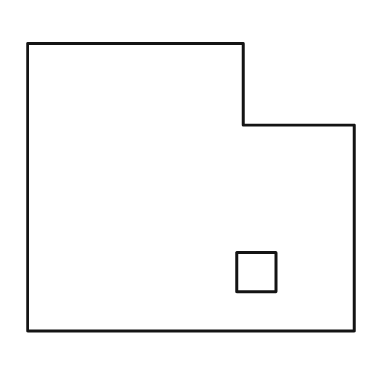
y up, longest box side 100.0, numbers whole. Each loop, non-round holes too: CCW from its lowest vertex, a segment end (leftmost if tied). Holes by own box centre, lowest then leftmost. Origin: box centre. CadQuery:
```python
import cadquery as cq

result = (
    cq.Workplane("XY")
    .moveTo(-50.0, -44.0)
    .lineTo(50.0, -44.0)
    .lineTo(50.0, 19.0)
    .lineTo(16.0, 19.0)
    .lineTo(16.0, 44.0)
    .lineTo(-50.0, 44.0)
    .close()
    .moveTo(14.0, -32.0)
    .lineTo(26.0, -32.0)
    .lineTo(26.0, -20.0)
    .lineTo(14.0, -20.0)
    .close()
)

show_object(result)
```